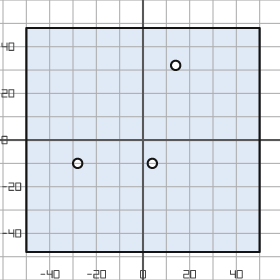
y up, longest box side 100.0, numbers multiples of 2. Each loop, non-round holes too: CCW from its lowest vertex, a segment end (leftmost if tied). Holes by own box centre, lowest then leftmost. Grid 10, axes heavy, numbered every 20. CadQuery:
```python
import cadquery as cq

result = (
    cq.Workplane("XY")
    .moveTo(-50.0, -48.0)
    .lineTo(50.0, -48.0)
    .lineTo(50.0, 48.0)
    .lineTo(-50.0, 48.0)
    .close()
    .moveTo(-28.0, -10.0)
    .circle(2.0)
    .moveTo(4.0, -10.0)
    .circle(2.0)
    .moveTo(14.0, 32.0)
    .circle(2.0)
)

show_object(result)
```